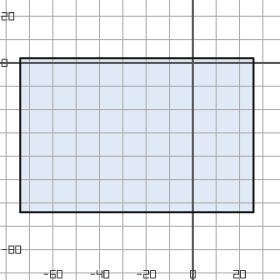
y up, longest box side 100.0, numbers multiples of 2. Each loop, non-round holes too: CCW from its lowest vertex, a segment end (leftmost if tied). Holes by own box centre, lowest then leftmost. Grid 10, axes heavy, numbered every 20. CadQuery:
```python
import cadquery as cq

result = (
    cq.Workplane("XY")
    .moveTo(-74.0, -64.0)
    .lineTo(26.0, -64.0)
    .lineTo(26.0, 2.0)
    .lineTo(-74.0, 2.0)
    .close()
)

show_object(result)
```